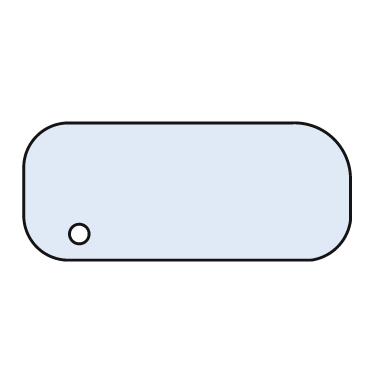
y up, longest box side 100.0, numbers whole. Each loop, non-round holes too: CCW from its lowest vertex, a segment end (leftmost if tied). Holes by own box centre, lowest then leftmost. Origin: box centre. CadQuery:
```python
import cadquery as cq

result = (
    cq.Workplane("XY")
    .moveTo(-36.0, -21.0)
    .lineTo(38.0, -21.0)
    .threePointArc((46.0, -17.0), (50.0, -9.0))
    .lineTo(50.0, 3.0)
    .threePointArc((45.0, 16.0), (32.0, 21.0))
    .lineTo(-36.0, 21.0)
    .threePointArc((-46.0, 17.0), (-50.0, 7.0))
    .lineTo(-50.0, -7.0)
    .threePointArc((-46.0, -17.0), (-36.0, -21.0))
    .close()
    .moveTo(-33.0, -13.0)
    .circle(3.0)
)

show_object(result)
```